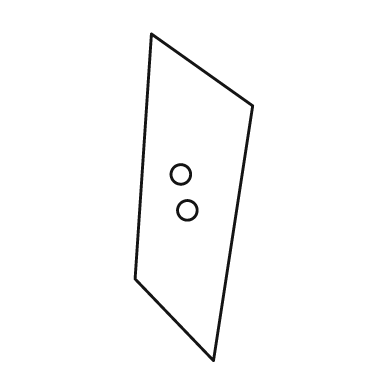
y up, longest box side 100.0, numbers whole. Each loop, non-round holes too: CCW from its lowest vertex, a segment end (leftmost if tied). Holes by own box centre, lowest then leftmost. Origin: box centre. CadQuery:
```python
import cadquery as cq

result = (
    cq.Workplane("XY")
    .moveTo(6.0, -50.0)
    .lineTo(18.0, 28.0)
    .lineTo(-13.0, 50.0)
    .lineTo(-18.0, -25.0)
    .close()
    .moveTo(-2.0, -4.0)
    .circle(3.0)
    .moveTo(-4.0, 7.0)
    .circle(3.0)
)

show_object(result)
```